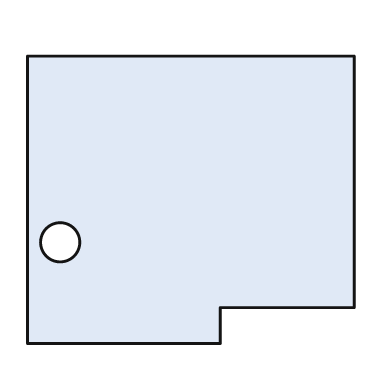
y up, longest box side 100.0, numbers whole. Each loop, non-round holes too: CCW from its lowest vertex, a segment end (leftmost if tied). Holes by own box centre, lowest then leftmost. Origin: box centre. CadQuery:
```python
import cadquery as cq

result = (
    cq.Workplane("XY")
    .moveTo(-50.0, -44.0)
    .lineTo(9.0, -44.0)
    .lineTo(9.0, -33.0)
    .lineTo(50.0, -33.0)
    .lineTo(50.0, 44.0)
    .lineTo(-50.0, 44.0)
    .close()
    .moveTo(-40.0, -13.0)
    .circle(6.0)
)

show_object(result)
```